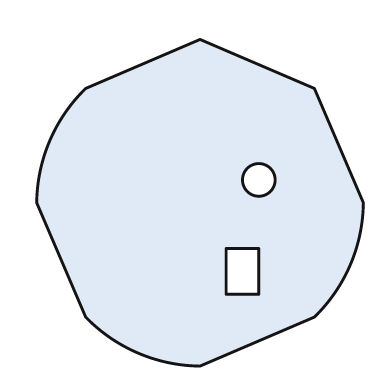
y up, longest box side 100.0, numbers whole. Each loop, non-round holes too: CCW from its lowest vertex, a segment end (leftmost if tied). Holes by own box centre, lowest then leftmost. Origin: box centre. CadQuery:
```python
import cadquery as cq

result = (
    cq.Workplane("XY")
    .moveTo(0.0, -50.0)
    .lineTo(35.0, -35.0)
    .threePointArc((46.0, -19.0), (50.0, 0.0))
    .lineTo(35.0, 35.0)
    .lineTo(0.0, 50.0)
    .lineTo(-35.0, 35.0)
    .threePointArc((-46.0, 19.0), (-50.0, 0.0))
    .lineTo(-35.0, -35.0)
    .threePointArc((-19.0, -46.0), (0.0, -50.0))
    .close()
    .moveTo(8.0, -28.0)
    .lineTo(18.0, -28.0)
    .lineTo(18.0, -14.0)
    .lineTo(8.0, -14.0)
    .close()
    .moveTo(18.0, 7.0)
    .circle(5.0)
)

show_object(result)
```